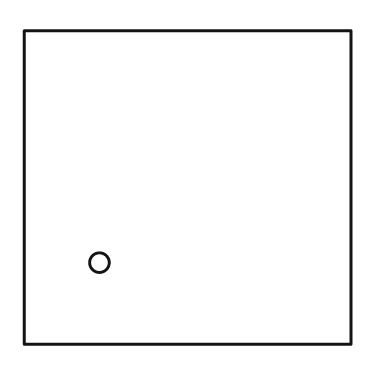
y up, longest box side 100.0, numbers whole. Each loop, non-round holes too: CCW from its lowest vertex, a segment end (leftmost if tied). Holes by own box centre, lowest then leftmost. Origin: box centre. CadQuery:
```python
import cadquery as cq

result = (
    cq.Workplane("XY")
    .moveTo(-50.0, -48.0)
    .lineTo(50.0, -48.0)
    .lineTo(50.0, 48.0)
    .lineTo(-50.0, 48.0)
    .close()
    .moveTo(-27.0, -23.0)
    .circle(3.0)
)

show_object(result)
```